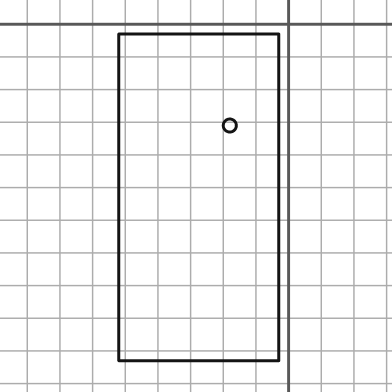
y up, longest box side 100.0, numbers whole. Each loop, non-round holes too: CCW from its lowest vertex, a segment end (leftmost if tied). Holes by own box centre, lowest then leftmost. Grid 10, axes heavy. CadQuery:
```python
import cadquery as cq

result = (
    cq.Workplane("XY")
    .moveTo(-52.0, -103.0)
    .lineTo(-3.0, -103.0)
    .lineTo(-3.0, -3.0)
    .lineTo(-52.0, -3.0)
    .close()
    .moveTo(-18.0, -31.0)
    .circle(2.0)
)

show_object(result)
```